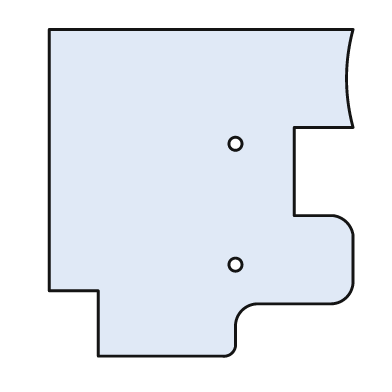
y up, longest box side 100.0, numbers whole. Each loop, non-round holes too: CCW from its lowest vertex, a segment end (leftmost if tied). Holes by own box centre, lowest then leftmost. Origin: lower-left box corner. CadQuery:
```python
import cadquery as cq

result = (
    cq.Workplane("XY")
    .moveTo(15.0, 0.0)
    .lineTo(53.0, 0.0)
    .threePointArc((56.0, 1.0), (57.0, 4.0))
    .lineTo(57.0, 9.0)
    .threePointArc((59.0, 14.0), (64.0, 16.0))
    .lineTo(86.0, 16.0)
    .threePointArc((91.0, 18.0), (93.0, 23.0))
    .lineTo(93.0, 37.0)
    .threePointArc((91.0, 41.0), (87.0, 43.0))
    .lineTo(75.0, 43.0)
    .lineTo(75.0, 70.0)
    .lineTo(93.0, 70.0)
    .threePointArc((91.0, 85.0), (93.0, 100.0))
    .lineTo(0.0, 100.0)
    .lineTo(0.0, 20.0)
    .lineTo(15.0, 20.0)
    .close()
    .moveTo(57.0, 28.0)
    .circle(2.0)
    .moveTo(57.0, 65.0)
    .circle(2.0)
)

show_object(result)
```